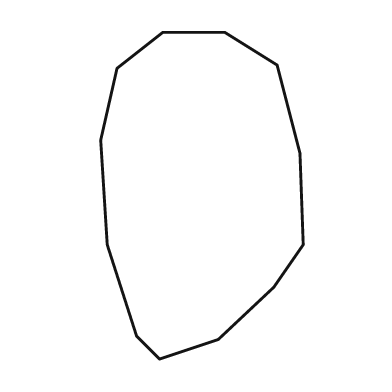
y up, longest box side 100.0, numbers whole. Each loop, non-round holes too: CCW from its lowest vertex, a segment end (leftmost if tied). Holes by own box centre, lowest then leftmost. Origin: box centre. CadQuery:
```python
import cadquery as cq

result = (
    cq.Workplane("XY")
    .moveTo(-13.0, -50.0)
    .lineTo(5.0, -44.0)
    .lineTo(22.0, -28.0)
    .lineTo(31.0, -15.0)
    .lineTo(30.0, 13.0)
    .lineTo(23.0, 40.0)
    .lineTo(7.0, 50.0)
    .lineTo(-12.0, 50.0)
    .lineTo(-26.0, 39.0)
    .lineTo(-31.0, 17.0)
    .lineTo(-29.0, -15.0)
    .lineTo(-20.0, -43.0)
    .close()
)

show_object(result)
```